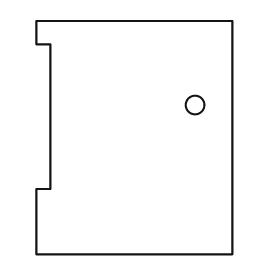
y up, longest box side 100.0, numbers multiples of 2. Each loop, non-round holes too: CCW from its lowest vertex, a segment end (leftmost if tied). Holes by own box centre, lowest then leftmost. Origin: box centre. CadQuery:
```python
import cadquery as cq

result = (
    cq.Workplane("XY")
    .moveTo(-42.0, -50.0)
    .lineTo(42.0, -50.0)
    .lineTo(42.0, 50.0)
    .lineTo(-42.0, 50.0)
    .lineTo(-42.0, 40.0)
    .lineTo(-36.0, 40.0)
    .lineTo(-36.0, -22.0)
    .lineTo(-42.0, -22.0)
    .close()
    .moveTo(26.0, 14.0)
    .circle(4.0)
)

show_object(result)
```